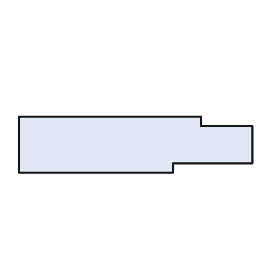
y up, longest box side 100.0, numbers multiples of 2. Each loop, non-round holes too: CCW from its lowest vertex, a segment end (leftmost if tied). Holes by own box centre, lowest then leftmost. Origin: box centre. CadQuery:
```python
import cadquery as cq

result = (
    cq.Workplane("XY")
    .moveTo(-50.0, -12.0)
    .lineTo(16.0, -12.0)
    .lineTo(16.0, -8.0)
    .lineTo(50.0, -8.0)
    .lineTo(50.0, 8.0)
    .lineTo(28.0, 8.0)
    .lineTo(28.0, 12.0)
    .lineTo(-50.0, 12.0)
    .close()
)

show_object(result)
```